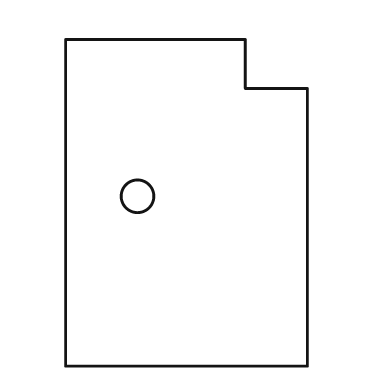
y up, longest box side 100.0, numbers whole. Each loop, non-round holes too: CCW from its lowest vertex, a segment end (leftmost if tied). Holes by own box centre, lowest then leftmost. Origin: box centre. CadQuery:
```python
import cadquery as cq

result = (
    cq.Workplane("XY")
    .moveTo(-37.0, -50.0)
    .lineTo(37.0, -50.0)
    .lineTo(37.0, 35.0)
    .lineTo(18.0, 35.0)
    .lineTo(18.0, 50.0)
    .lineTo(-37.0, 50.0)
    .close()
    .moveTo(-15.0, 2.0)
    .circle(5.0)
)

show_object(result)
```